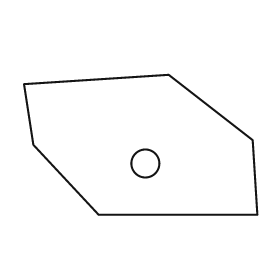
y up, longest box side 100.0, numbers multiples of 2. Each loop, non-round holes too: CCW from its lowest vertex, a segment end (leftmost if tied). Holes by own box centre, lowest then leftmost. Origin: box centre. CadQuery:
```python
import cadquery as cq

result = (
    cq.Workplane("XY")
    .moveTo(-18.0, -30.0)
    .lineTo(50.0, -30.0)
    .lineTo(48.0, 2.0)
    .lineTo(12.0, 30.0)
    .lineTo(-50.0, 26.0)
    .lineTo(-46.0, 0.0)
    .close()
    .moveTo(2.0, -8.0)
    .circle(6.0)
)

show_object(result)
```